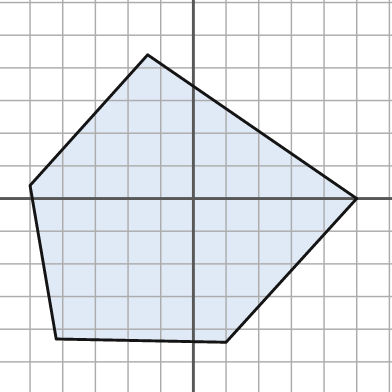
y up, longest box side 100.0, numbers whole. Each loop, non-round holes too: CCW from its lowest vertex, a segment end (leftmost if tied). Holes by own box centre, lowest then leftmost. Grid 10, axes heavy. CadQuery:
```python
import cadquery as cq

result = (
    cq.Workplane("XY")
    .moveTo(10.0, -44.0)
    .lineTo(50.0, 0.0)
    .lineTo(-14.0, 44.0)
    .lineTo(-50.0, 4.0)
    .lineTo(-42.0, -43.0)
    .close()
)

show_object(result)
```